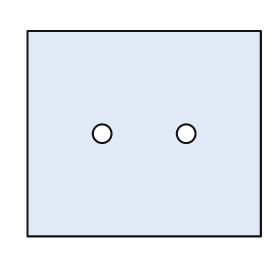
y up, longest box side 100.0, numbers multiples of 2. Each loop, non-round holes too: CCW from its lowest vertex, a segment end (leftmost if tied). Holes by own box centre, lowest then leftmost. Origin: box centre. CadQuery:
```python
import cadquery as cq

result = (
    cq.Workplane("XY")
    .moveTo(-50.0, -44.0)
    .lineTo(50.0, -44.0)
    .lineTo(50.0, 44.0)
    .lineTo(-50.0, 44.0)
    .close()
    .moveTo(-18.0, 0.0)
    .circle(4.0)
    .moveTo(18.0, 0.0)
    .circle(4.0)
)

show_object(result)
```